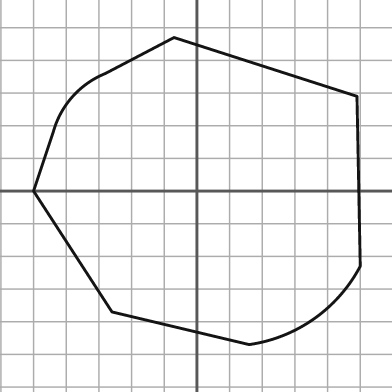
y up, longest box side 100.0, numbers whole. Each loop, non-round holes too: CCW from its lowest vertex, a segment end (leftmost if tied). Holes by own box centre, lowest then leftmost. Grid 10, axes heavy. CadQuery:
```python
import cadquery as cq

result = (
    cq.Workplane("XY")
    .moveTo(16.0, -47.0)
    .threePointArc((36.0, -39.0), (50.0, -23.0))
    .lineTo(49.0, 29.0)
    .lineTo(-7.0, 47.0)
    .lineTo(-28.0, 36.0)
    .threePointArc((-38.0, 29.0), (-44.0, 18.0))
    .lineTo(-50.0, 0.0)
    .lineTo(-26.0, -37.0)
    .close()
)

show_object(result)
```